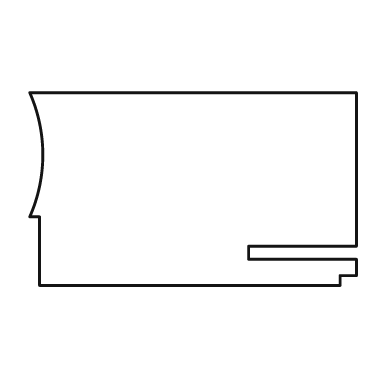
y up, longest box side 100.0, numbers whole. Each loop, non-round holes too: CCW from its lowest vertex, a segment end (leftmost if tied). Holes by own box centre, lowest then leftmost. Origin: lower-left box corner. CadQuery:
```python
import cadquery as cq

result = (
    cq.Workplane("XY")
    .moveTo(3.0, 0.0)
    .lineTo(95.0, 0.0)
    .lineTo(95.0, 3.0)
    .lineTo(100.0, 3.0)
    .lineTo(100.0, 8.0)
    .lineTo(67.0, 8.0)
    .lineTo(67.0, 12.0)
    .lineTo(100.0, 12.0)
    .lineTo(100.0, 59.0)
    .lineTo(0.0, 59.0)
    .threePointArc((4.0, 40.0), (0.0, 21.0))
    .lineTo(3.0, 21.0)
    .close()
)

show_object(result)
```